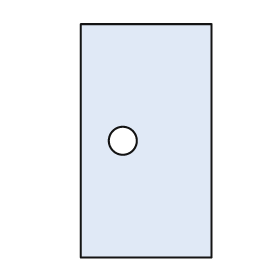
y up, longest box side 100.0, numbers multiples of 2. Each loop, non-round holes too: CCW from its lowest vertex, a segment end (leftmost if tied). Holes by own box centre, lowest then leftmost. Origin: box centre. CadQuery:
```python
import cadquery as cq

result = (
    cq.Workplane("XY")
    .moveTo(-28.0, -50.0)
    .lineTo(28.0, -50.0)
    .lineTo(28.0, 50.0)
    .lineTo(-28.0, 50.0)
    .close()
    .moveTo(-10.0, 0.0)
    .circle(6.0)
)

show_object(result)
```